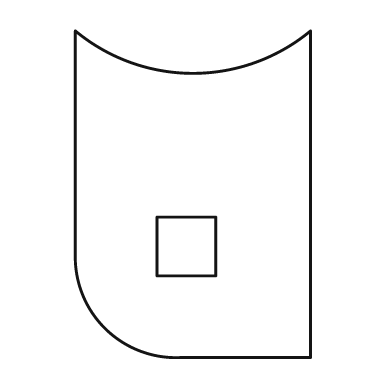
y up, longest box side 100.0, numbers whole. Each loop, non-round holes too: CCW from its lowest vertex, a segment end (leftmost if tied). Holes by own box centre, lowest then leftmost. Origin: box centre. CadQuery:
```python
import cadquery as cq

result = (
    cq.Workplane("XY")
    .moveTo(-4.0, -50.0)
    .lineTo(36.0, -50.0)
    .lineTo(36.0, 50.0)
    .threePointArc((0.0, 37.0), (-36.0, 50.0))
    .lineTo(-36.0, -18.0)
    .threePointArc((-27.0, -41.0), (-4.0, -50.0))
    .close()
    .moveTo(-11.0, -25.0)
    .lineTo(7.0, -25.0)
    .lineTo(7.0, -7.0)
    .lineTo(-11.0, -7.0)
    .close()
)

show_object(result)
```